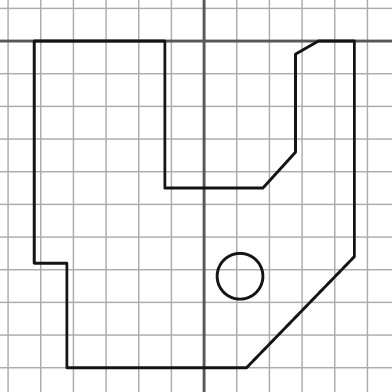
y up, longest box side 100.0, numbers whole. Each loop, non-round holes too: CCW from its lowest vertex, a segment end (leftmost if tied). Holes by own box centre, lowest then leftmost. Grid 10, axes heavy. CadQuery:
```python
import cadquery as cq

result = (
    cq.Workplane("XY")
    .moveTo(-42.0, -100.0)
    .lineTo(13.0, -100.0)
    .lineTo(46.0, -66.0)
    .lineTo(46.0, 0.0)
    .lineTo(35.0, 0.0)
    .lineTo(28.0, -4.0)
    .lineTo(28.0, -34.0)
    .lineTo(18.0, -45.0)
    .lineTo(-12.0, -45.0)
    .lineTo(-12.0, 0.0)
    .lineTo(-52.0, 0.0)
    .lineTo(-52.0, -68.0)
    .lineTo(-42.0, -68.0)
    .close()
    .moveTo(11.0, -72.0)
    .circle(7.0)
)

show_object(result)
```